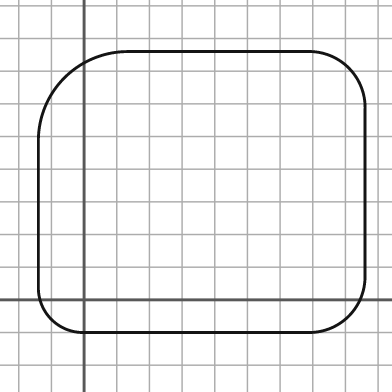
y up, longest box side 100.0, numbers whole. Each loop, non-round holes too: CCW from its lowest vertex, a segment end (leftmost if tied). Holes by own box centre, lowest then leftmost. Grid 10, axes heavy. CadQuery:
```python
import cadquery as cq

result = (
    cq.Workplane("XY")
    .moveTo(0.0, -10.0)
    .lineTo(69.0, -10.0)
    .threePointArc((81.0, -5.0), (86.0, 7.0))
    .lineTo(86.0, 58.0)
    .threePointArc((81.0, 71.0), (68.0, 76.0))
    .lineTo(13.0, 76.0)
    .threePointArc((-6.0, 68.0), (-14.0, 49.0))
    .lineTo(-14.0, 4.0)
    .threePointArc((-10.0, -6.0), (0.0, -10.0))
    .close()
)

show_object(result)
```